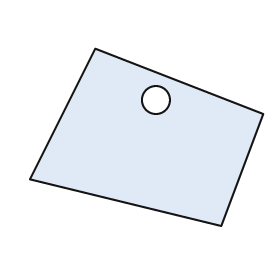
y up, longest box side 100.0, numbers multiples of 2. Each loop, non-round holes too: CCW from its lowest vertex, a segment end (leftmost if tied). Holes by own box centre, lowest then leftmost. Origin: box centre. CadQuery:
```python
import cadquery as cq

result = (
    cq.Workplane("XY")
    .moveTo(32.0, -38.0)
    .lineTo(50.0, 10.0)
    .lineTo(-22.0, 38.0)
    .lineTo(-50.0, -18.0)
    .close()
    .moveTo(4.0, 16.0)
    .circle(6.0)
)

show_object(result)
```